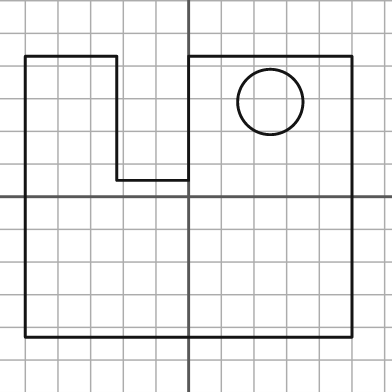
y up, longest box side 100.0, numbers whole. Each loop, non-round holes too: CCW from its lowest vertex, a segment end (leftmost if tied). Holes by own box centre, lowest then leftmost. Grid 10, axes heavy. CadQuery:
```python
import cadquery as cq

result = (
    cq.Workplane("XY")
    .moveTo(-50.0, -43.0)
    .lineTo(50.0, -43.0)
    .lineTo(50.0, 43.0)
    .lineTo(0.0, 43.0)
    .lineTo(0.0, 5.0)
    .lineTo(-22.0, 5.0)
    .lineTo(-22.0, 43.0)
    .lineTo(-50.0, 43.0)
    .close()
    .moveTo(25.0, 29.0)
    .circle(10.0)
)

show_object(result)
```